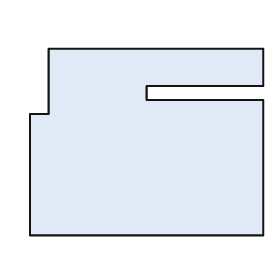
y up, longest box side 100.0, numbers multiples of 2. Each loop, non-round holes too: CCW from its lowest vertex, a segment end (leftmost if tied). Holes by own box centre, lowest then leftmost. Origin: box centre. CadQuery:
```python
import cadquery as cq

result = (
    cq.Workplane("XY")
    .moveTo(-50.0, -40.0)
    .lineTo(50.0, -40.0)
    .lineTo(50.0, 18.0)
    .lineTo(0.0, 18.0)
    .lineTo(0.0, 24.0)
    .lineTo(50.0, 24.0)
    .lineTo(50.0, 40.0)
    .lineTo(-42.0, 40.0)
    .lineTo(-42.0, 12.0)
    .lineTo(-50.0, 12.0)
    .close()
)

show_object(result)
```